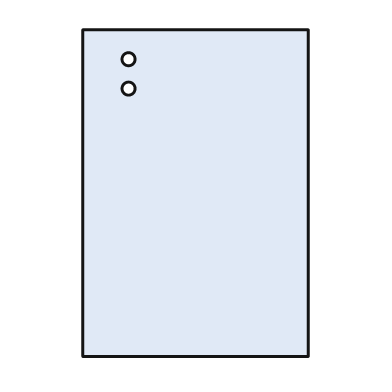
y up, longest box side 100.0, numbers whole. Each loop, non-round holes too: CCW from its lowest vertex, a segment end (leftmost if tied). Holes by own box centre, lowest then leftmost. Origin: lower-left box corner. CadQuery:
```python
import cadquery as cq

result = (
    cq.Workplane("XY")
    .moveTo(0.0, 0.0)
    .lineTo(69.0, 0.0)
    .lineTo(69.0, 100.0)
    .lineTo(0.0, 100.0)
    .close()
    .moveTo(14.0, 82.0)
    .circle(2.0)
    .moveTo(14.0, 91.0)
    .circle(2.0)
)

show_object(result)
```